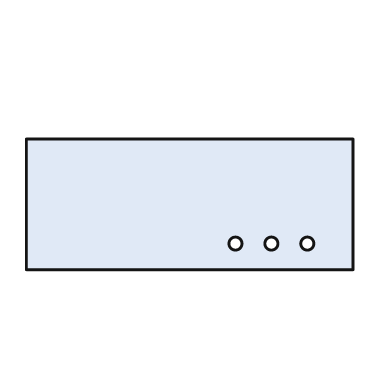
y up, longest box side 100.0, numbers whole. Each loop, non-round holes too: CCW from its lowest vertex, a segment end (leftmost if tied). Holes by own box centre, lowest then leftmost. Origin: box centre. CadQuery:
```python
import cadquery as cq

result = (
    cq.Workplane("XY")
    .moveTo(-50.0, -20.0)
    .lineTo(50.0, -20.0)
    .lineTo(50.0, 20.0)
    .lineTo(-50.0, 20.0)
    .close()
    .moveTo(14.0, -12.0)
    .circle(2.0)
    .moveTo(25.0, -12.0)
    .circle(2.0)
    .moveTo(36.0, -12.0)
    .circle(2.0)
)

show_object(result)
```